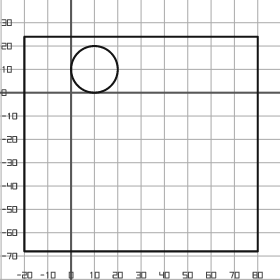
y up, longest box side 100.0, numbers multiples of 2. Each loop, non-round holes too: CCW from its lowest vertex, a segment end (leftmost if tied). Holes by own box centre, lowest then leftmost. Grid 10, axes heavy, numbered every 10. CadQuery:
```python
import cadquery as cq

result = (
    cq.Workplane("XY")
    .moveTo(-20.0, -68.0)
    .lineTo(80.0, -68.0)
    .lineTo(80.0, 24.0)
    .lineTo(-20.0, 24.0)
    .close()
    .moveTo(10.0, 10.0)
    .circle(10.0)
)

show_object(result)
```